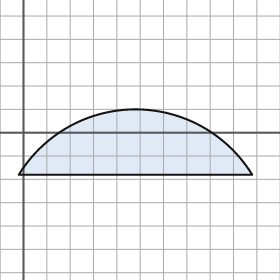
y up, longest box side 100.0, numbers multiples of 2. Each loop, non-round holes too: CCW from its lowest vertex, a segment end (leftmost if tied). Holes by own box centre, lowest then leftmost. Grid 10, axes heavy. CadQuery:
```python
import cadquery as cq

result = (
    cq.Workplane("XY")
    .moveTo(-2.0, -18.0)
    .lineTo(98.0, -18.0)
    .threePointArc((48.0, 10.0), (-2.0, -18.0))
    .close()
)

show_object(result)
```